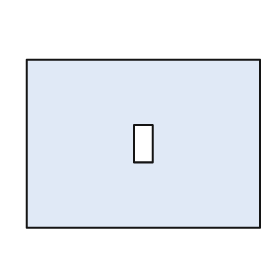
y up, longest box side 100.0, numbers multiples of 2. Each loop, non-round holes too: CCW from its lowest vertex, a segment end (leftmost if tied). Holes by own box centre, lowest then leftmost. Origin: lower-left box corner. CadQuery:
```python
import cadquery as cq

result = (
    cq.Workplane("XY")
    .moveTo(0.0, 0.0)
    .lineTo(100.0, 0.0)
    .lineTo(100.0, 72.0)
    .lineTo(0.0, 72.0)
    .close()
    .moveTo(46.0, 28.0)
    .lineTo(54.0, 28.0)
    .lineTo(54.0, 44.0)
    .lineTo(46.0, 44.0)
    .close()
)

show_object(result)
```